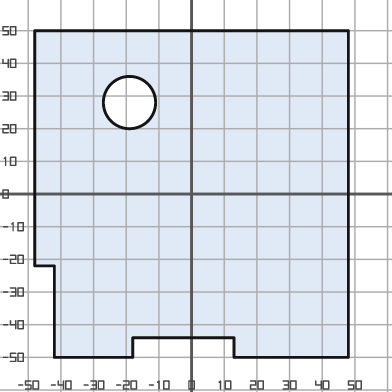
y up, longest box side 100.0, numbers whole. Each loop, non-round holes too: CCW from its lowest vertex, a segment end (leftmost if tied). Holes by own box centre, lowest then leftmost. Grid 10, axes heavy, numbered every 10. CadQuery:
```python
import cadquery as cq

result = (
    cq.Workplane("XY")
    .moveTo(-42.0, -50.0)
    .lineTo(-18.0, -50.0)
    .lineTo(-18.0, -44.0)
    .lineTo(13.0, -44.0)
    .lineTo(13.0, -50.0)
    .lineTo(48.0, -50.0)
    .lineTo(48.0, 50.0)
    .lineTo(-48.0, 50.0)
    .lineTo(-48.0, -22.0)
    .lineTo(-42.0, -22.0)
    .close()
    .moveTo(-19.0, 28.0)
    .circle(8.0)
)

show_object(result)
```